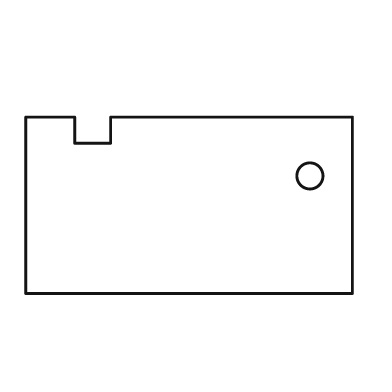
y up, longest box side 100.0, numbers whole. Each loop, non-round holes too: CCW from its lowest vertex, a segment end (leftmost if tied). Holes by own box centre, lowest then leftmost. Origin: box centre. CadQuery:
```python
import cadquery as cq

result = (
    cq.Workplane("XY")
    .moveTo(-50.0, -27.0)
    .lineTo(50.0, -27.0)
    .lineTo(50.0, 27.0)
    .lineTo(-24.0, 27.0)
    .lineTo(-24.0, 19.0)
    .lineTo(-35.0, 19.0)
    .lineTo(-35.0, 27.0)
    .lineTo(-50.0, 27.0)
    .close()
    .moveTo(37.0, 9.0)
    .circle(4.0)
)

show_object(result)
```